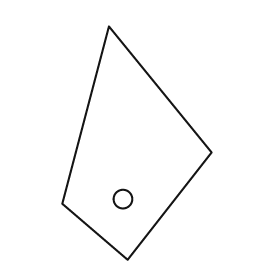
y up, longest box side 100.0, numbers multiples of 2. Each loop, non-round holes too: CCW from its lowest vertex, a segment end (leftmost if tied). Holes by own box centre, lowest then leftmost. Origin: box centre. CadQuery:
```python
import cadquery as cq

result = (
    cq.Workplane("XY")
    .moveTo(-4.0, -50.0)
    .lineTo(32.0, -4.0)
    .lineTo(-12.0, 50.0)
    .lineTo(-32.0, -26.0)
    .close()
    .moveTo(-6.0, -24.0)
    .circle(4.0)
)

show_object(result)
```